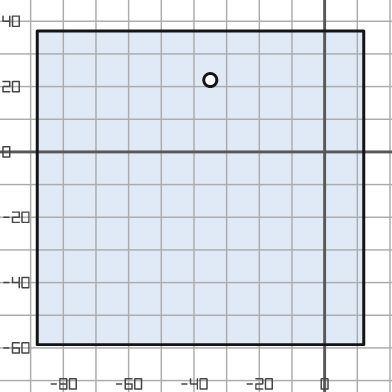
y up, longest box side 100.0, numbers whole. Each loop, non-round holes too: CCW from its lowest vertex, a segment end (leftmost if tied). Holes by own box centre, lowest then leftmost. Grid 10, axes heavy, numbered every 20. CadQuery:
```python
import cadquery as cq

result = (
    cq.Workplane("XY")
    .moveTo(-88.0, -59.0)
    .lineTo(12.0, -59.0)
    .lineTo(12.0, 37.0)
    .lineTo(-88.0, 37.0)
    .close()
    .moveTo(-35.0, 22.0)
    .circle(2.0)
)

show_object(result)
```